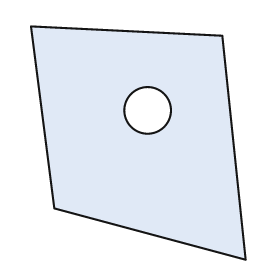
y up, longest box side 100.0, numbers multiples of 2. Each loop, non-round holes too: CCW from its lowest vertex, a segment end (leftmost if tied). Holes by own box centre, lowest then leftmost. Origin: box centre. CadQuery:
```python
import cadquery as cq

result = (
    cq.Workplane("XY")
    .moveTo(46.0, -50.0)
    .lineTo(36.0, 46.0)
    .lineTo(-46.0, 50.0)
    .lineTo(-36.0, -28.0)
    .close()
    .moveTo(4.0, 14.0)
    .circle(10.0)
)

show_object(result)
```